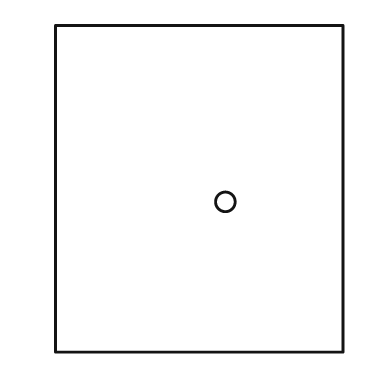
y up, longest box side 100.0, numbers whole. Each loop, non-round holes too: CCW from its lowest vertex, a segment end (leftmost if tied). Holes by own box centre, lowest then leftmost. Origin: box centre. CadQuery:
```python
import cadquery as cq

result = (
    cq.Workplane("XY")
    .moveTo(-44.0, -50.0)
    .lineTo(44.0, -50.0)
    .lineTo(44.0, 50.0)
    .lineTo(-44.0, 50.0)
    .close()
    .moveTo(8.0, -4.0)
    .circle(3.0)
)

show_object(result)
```